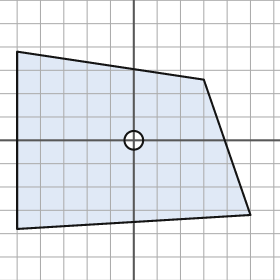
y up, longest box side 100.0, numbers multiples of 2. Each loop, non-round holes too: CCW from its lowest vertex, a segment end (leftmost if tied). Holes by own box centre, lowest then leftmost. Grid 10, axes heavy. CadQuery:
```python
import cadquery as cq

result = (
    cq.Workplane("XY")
    .moveTo(-50.0, -38.0)
    .lineTo(50.0, -32.0)
    .lineTo(30.0, 26.0)
    .lineTo(-50.0, 38.0)
    .close()
    .moveTo(0.0, 0.0)
    .circle(4.0)
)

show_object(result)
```